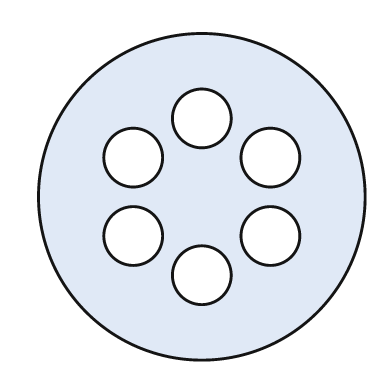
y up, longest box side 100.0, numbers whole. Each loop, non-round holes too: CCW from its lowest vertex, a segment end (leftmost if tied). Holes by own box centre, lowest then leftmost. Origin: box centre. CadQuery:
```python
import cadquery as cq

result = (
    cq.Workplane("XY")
    .moveTo(0.0, 0.0)
    .circle(50.0)
    .moveTo(0.0, -24.0)
    .circle(9.0)
    .moveTo(-21.0, -12.0)
    .circle(9.0)
    .moveTo(21.0, -12.0)
    .circle(9.0)
    .moveTo(-21.0, 12.0)
    .circle(9.0)
    .moveTo(21.0, 12.0)
    .circle(9.0)
    .moveTo(0.0, 24.0)
    .circle(9.0)
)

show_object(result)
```